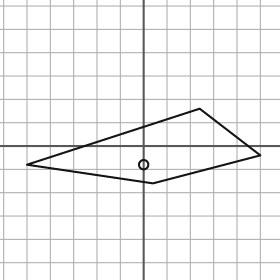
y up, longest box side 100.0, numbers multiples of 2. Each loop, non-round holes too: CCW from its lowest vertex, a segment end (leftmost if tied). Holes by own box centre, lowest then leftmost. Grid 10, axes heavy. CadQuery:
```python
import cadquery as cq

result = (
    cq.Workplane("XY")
    .moveTo(4.0, -16.0)
    .lineTo(50.0, -4.0)
    .lineTo(24.0, 16.0)
    .lineTo(-50.0, -8.0)
    .close()
    .moveTo(0.0, -8.0)
    .circle(2.0)
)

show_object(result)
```